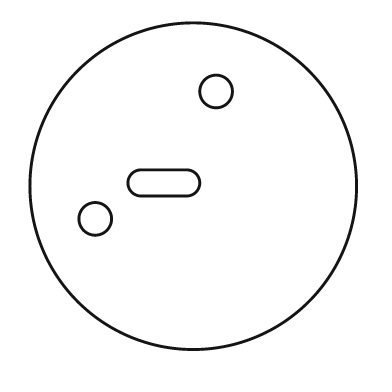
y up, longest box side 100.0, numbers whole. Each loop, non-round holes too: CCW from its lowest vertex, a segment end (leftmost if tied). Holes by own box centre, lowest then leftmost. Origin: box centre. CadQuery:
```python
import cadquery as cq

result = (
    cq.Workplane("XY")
    .moveTo(0.0, 0.0)
    .circle(50.0)
    .moveTo(-30.0, -10.0)
    .circle(5.0)
    .moveTo(-16.0, -3.0)
    .lineTo(-2.0, -3.0)
    .threePointArc((2.0, 1.0), (-2.0, 5.0))
    .lineTo(-16.0, 5.0)
    .threePointArc((-20.0, 1.0), (-16.0, -3.0))
    .close()
    .moveTo(7.0, 29.0)
    .circle(5.0)
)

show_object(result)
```